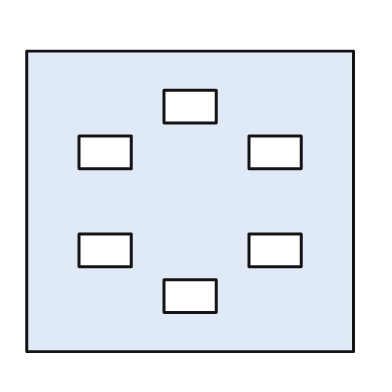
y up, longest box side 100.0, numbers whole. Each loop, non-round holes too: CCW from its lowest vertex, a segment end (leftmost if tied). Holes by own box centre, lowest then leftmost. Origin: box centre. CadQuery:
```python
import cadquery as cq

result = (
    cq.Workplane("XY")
    .moveTo(-50.0, -46.0)
    .lineTo(50.0, -46.0)
    .lineTo(50.0, 46.0)
    .lineTo(-50.0, 46.0)
    .close()
    .moveTo(-8.0, -34.0)
    .lineTo(8.0, -34.0)
    .lineTo(8.0, -24.0)
    .lineTo(-8.0, -24.0)
    .close()
    .moveTo(-34.0, -20.0)
    .lineTo(-18.0, -20.0)
    .lineTo(-18.0, -10.0)
    .lineTo(-34.0, -10.0)
    .close()
    .moveTo(18.0, -20.0)
    .lineTo(34.0, -20.0)
    .lineTo(34.0, -10.0)
    .lineTo(18.0, -10.0)
    .close()
    .moveTo(-34.0, 10.0)
    .lineTo(-18.0, 10.0)
    .lineTo(-18.0, 20.0)
    .lineTo(-34.0, 20.0)
    .close()
    .moveTo(18.0, 10.0)
    .lineTo(34.0, 10.0)
    .lineTo(34.0, 20.0)
    .lineTo(18.0, 20.0)
    .close()
    .moveTo(-8.0, 24.0)
    .lineTo(8.0, 24.0)
    .lineTo(8.0, 34.0)
    .lineTo(-8.0, 34.0)
    .close()
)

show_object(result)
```